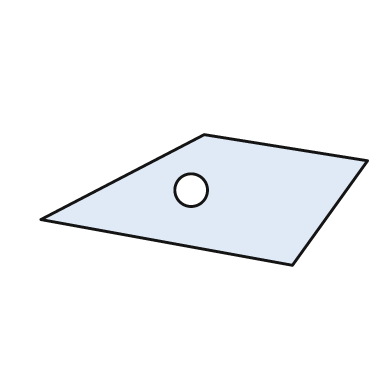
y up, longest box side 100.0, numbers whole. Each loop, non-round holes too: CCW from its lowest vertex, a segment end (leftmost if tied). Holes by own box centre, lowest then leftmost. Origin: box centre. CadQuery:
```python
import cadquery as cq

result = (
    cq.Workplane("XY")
    .moveTo(27.0, -20.0)
    .lineTo(50.0, 12.0)
    .lineTo(0.0, 20.0)
    .lineTo(-50.0, -6.0)
    .close()
    .moveTo(-4.0, 3.0)
    .circle(5.0)
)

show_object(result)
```